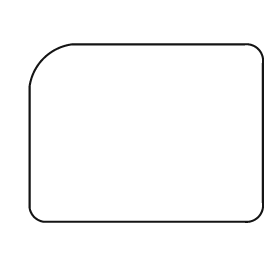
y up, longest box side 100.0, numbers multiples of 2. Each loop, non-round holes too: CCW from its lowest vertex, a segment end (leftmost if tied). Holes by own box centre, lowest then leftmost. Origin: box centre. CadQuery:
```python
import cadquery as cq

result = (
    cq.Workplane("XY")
    .moveTo(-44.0, -38.0)
    .lineTo(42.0, -38.0)
    .threePointArc((48.0, -36.0), (50.0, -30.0))
    .lineTo(50.0, 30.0)
    .threePointArc((48.0, 36.0), (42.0, 38.0))
    .lineTo(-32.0, 38.0)
    .threePointArc((-44.0, 32.0), (-50.0, 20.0))
    .lineTo(-50.0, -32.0)
    .threePointArc((-48.0, -36.0), (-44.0, -38.0))
    .close()
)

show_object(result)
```